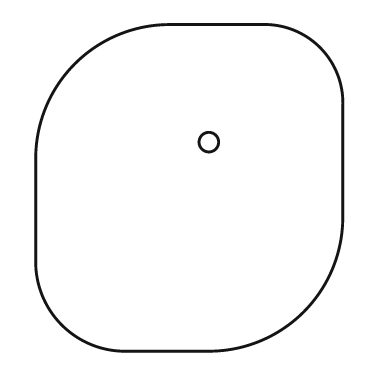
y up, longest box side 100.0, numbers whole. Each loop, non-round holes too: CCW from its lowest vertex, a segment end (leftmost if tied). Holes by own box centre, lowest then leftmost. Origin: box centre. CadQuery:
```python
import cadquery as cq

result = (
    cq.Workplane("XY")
    .moveTo(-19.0, -50.0)
    .lineTo(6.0, -50.0)
    .threePointArc((35.0, -38.0), (47.0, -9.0))
    .lineTo(47.0, 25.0)
    .threePointArc((40.0, 43.0), (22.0, 50.0))
    .lineTo(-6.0, 50.0)
    .threePointArc((-35.0, 38.0), (-47.0, 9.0))
    .lineTo(-47.0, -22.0)
    .threePointArc((-39.0, -42.0), (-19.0, -50.0))
    .close()
    .moveTo(6.0, 14.0)
    .circle(3.0)
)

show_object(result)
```